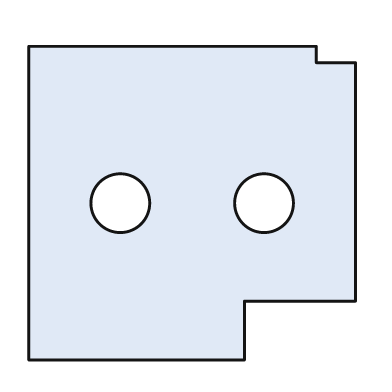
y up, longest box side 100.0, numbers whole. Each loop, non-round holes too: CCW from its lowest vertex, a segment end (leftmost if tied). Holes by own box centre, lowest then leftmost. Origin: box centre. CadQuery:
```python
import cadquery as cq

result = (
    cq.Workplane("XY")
    .moveTo(-50.0, -48.0)
    .lineTo(16.0, -48.0)
    .lineTo(16.0, -30.0)
    .lineTo(50.0, -30.0)
    .lineTo(50.0, 43.0)
    .lineTo(38.0, 43.0)
    .lineTo(38.0, 48.0)
    .lineTo(-50.0, 48.0)
    .close()
    .moveTo(-22.0, 0.0)
    .circle(9.0)
    .moveTo(22.0, 0.0)
    .circle(9.0)
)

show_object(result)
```